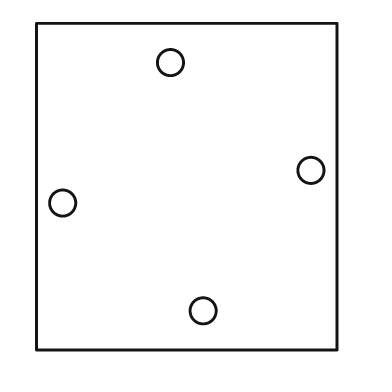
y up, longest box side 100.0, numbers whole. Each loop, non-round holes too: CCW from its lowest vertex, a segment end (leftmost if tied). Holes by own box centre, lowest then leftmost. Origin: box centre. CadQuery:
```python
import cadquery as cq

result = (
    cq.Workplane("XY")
    .moveTo(-46.0, -50.0)
    .lineTo(46.0, -50.0)
    .lineTo(46.0, 50.0)
    .lineTo(-46.0, 50.0)
    .close()
    .moveTo(5.0, -38.0)
    .circle(4.0)
    .moveTo(-38.0, -5.0)
    .circle(4.0)
    .moveTo(38.0, 5.0)
    .circle(4.0)
    .moveTo(-5.0, 38.0)
    .circle(4.0)
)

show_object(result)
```